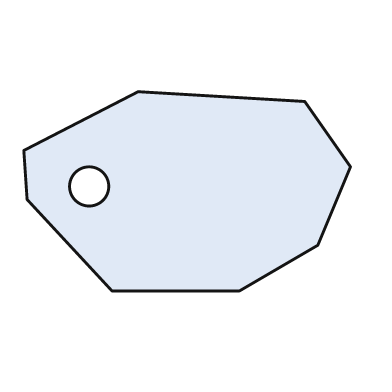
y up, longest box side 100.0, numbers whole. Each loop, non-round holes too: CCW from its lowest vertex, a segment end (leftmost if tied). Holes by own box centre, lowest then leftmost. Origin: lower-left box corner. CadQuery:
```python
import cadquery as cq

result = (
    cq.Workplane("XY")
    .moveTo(27.0, 0.0)
    .lineTo(66.0, 0.0)
    .lineTo(90.0, 14.0)
    .lineTo(100.0, 38.0)
    .lineTo(86.0, 58.0)
    .lineTo(35.0, 61.0)
    .lineTo(0.0, 43.0)
    .lineTo(1.0, 28.0)
    .close()
    .moveTo(20.0, 32.0)
    .circle(6.0)
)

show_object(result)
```